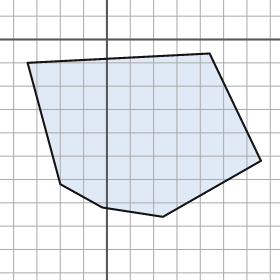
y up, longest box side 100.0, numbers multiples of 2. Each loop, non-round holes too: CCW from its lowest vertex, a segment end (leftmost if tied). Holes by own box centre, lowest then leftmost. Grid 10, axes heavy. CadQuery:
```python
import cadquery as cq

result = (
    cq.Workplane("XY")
    .moveTo(24.0, -76.0)
    .lineTo(66.0, -52.0)
    .lineTo(44.0, -6.0)
    .lineTo(-34.0, -10.0)
    .lineTo(-20.0, -62.0)
    .lineTo(-2.0, -72.0)
    .close()
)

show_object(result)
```